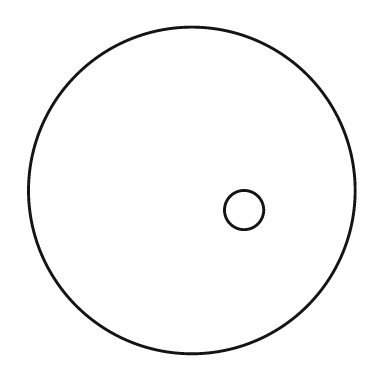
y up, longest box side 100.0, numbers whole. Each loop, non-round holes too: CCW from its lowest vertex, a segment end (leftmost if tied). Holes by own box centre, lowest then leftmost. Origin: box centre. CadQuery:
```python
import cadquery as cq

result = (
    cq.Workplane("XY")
    .moveTo(0.0, 0.0)
    .circle(50.0)
    .moveTo(16.0, -6.0)
    .circle(6.0)
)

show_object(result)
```